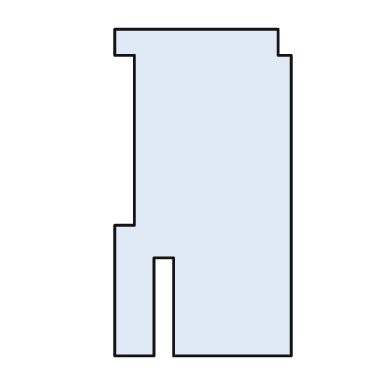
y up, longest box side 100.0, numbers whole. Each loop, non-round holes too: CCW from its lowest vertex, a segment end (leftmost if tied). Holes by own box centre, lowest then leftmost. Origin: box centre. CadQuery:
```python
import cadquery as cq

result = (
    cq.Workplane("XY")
    .moveTo(-27.0, -50.0)
    .lineTo(-15.0, -50.0)
    .lineTo(-15.0, -20.0)
    .lineTo(-9.0, -20.0)
    .lineTo(-9.0, -50.0)
    .lineTo(27.0, -50.0)
    .lineTo(27.0, 42.0)
    .lineTo(23.0, 42.0)
    .lineTo(23.0, 50.0)
    .lineTo(-27.0, 50.0)
    .lineTo(-27.0, 42.0)
    .lineTo(-21.0, 42.0)
    .lineTo(-21.0, -10.0)
    .lineTo(-27.0, -10.0)
    .close()
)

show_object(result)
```